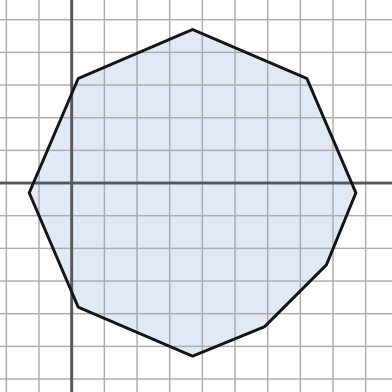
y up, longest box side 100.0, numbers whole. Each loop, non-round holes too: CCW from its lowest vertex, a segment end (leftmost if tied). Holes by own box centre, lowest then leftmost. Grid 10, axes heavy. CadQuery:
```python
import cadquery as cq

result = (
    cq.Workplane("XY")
    .moveTo(37.0, -53.0)
    .lineTo(59.0, -44.0)
    .lineTo(78.0, -25.0)
    .lineTo(87.0, -3.0)
    .lineTo(72.0, 32.0)
    .lineTo(37.0, 47.0)
    .lineTo(2.0, 32.0)
    .lineTo(-13.0, -3.0)
    .lineTo(2.0, -38.0)
    .close()
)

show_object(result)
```